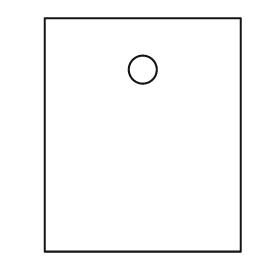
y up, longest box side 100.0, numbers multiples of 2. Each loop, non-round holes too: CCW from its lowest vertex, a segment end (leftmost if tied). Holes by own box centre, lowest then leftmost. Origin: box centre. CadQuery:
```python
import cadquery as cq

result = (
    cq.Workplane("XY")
    .moveTo(-42.0, -50.0)
    .lineTo(42.0, -50.0)
    .lineTo(42.0, 50.0)
    .lineTo(-42.0, 50.0)
    .close()
    .moveTo(0.0, 28.0)
    .circle(6.0)
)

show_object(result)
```